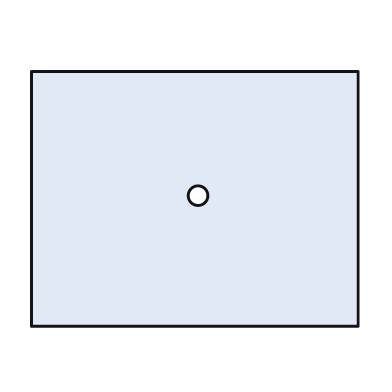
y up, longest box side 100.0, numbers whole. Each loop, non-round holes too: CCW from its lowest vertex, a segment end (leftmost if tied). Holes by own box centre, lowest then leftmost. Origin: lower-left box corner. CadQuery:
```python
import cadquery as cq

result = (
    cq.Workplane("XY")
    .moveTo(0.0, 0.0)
    .lineTo(100.0, 0.0)
    .lineTo(100.0, 78.0)
    .lineTo(0.0, 78.0)
    .close()
    .moveTo(51.0, 40.0)
    .circle(3.0)
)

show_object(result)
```